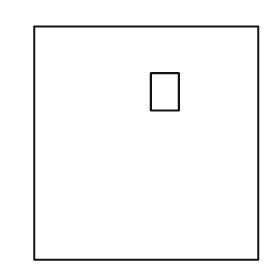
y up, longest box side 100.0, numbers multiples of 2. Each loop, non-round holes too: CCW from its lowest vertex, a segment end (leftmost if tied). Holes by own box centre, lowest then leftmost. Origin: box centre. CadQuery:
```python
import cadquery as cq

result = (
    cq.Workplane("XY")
    .moveTo(-48.0, -50.0)
    .lineTo(48.0, -50.0)
    .lineTo(48.0, 50.0)
    .lineTo(-48.0, 50.0)
    .close()
    .moveTo(2.0, 14.0)
    .lineTo(14.0, 14.0)
    .lineTo(14.0, 30.0)
    .lineTo(2.0, 30.0)
    .close()
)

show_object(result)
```